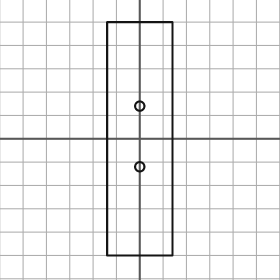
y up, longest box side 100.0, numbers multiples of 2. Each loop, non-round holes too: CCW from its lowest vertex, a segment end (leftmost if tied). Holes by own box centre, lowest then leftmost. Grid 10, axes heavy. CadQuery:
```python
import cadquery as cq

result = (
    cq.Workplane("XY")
    .moveTo(-14.0, -50.0)
    .lineTo(14.0, -50.0)
    .lineTo(14.0, 50.0)
    .lineTo(-14.0, 50.0)
    .close()
    .moveTo(0.0, -12.0)
    .circle(2.0)
    .moveTo(0.0, 14.0)
    .circle(2.0)
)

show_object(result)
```